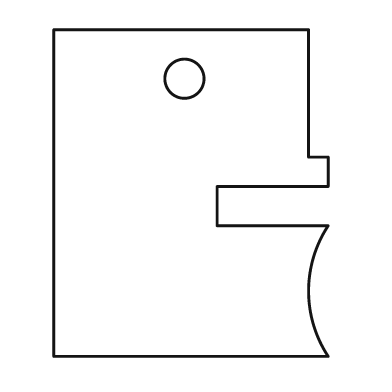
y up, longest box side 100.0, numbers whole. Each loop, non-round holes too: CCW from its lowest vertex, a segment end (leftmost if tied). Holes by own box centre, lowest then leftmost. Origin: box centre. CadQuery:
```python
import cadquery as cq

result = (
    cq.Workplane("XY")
    .moveTo(-42.0, -50.0)
    .lineTo(42.0, -50.0)
    .threePointArc((36.0, -30.0), (42.0, -10.0))
    .lineTo(8.0, -10.0)
    .lineTo(8.0, 2.0)
    .lineTo(42.0, 2.0)
    .lineTo(42.0, 11.0)
    .lineTo(36.0, 11.0)
    .lineTo(36.0, 50.0)
    .lineTo(-42.0, 50.0)
    .close()
    .moveTo(-2.0, 35.0)
    .circle(6.0)
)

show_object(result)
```